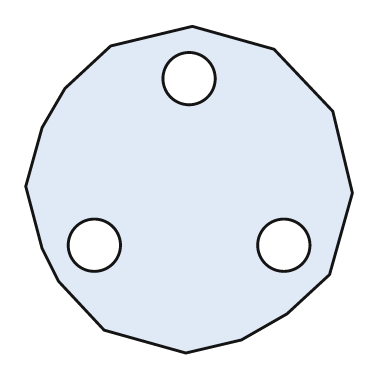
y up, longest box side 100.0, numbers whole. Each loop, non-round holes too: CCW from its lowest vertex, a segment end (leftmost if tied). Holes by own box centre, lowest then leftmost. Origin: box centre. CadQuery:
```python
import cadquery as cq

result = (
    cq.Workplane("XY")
    .moveTo(-1.0, -50.0)
    .lineTo(16.0, -46.0)
    .lineTo(30.0, -38.0)
    .lineTo(43.0, -26.0)
    .lineTo(50.0, -1.0)
    .lineTo(44.0, 24.0)
    .lineTo(26.0, 43.0)
    .lineTo(1.0, 50.0)
    .lineTo(-24.0, 44.0)
    .lineTo(-38.0, 31.0)
    .lineTo(-45.0, 19.0)
    .lineTo(-50.0, 1.0)
    .lineTo(-45.0, -18.0)
    .lineTo(-40.0, -28.0)
    .lineTo(-26.0, -43.0)
    .close()
    .moveTo(-29.0, -17.0)
    .circle(8.0)
    .moveTo(29.0, -17.0)
    .circle(8.0)
    .moveTo(0.0, 34.0)
    .circle(8.0)
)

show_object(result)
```